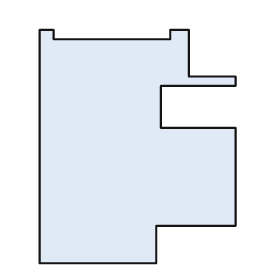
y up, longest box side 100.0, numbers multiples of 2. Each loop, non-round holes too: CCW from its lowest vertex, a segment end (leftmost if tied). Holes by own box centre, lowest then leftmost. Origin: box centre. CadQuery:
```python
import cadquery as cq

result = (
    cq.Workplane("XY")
    .moveTo(-42.0, -50.0)
    .lineTo(8.0, -50.0)
    .lineTo(8.0, -34.0)
    .lineTo(42.0, -34.0)
    .lineTo(42.0, 8.0)
    .lineTo(10.0, 8.0)
    .lineTo(10.0, 26.0)
    .lineTo(42.0, 26.0)
    .lineTo(42.0, 30.0)
    .lineTo(22.0, 30.0)
    .lineTo(22.0, 50.0)
    .lineTo(14.0, 50.0)
    .lineTo(14.0, 46.0)
    .lineTo(-36.0, 46.0)
    .lineTo(-36.0, 50.0)
    .lineTo(-42.0, 50.0)
    .close()
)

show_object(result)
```